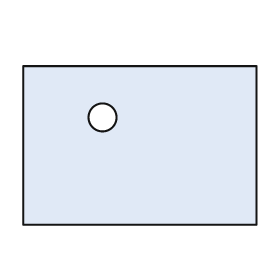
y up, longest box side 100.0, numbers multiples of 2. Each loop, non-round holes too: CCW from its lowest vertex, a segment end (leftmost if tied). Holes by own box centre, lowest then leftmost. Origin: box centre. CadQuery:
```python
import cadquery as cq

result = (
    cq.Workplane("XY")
    .moveTo(-50.0, -34.0)
    .lineTo(50.0, -34.0)
    .lineTo(50.0, 34.0)
    .lineTo(-50.0, 34.0)
    .close()
    .moveTo(-16.0, 12.0)
    .circle(6.0)
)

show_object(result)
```